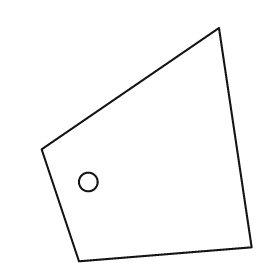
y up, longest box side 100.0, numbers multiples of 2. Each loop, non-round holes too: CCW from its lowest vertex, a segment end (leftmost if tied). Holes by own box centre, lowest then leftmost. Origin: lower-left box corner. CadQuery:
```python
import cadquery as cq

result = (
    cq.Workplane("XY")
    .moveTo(16.0, 0.0)
    .lineTo(90.0, 6.0)
    .lineTo(76.0, 100.0)
    .lineTo(0.0, 48.0)
    .close()
    .moveTo(20.0, 34.0)
    .circle(4.0)
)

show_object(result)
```